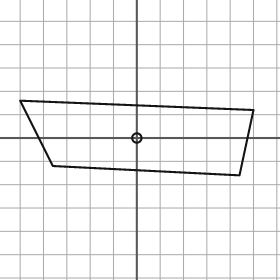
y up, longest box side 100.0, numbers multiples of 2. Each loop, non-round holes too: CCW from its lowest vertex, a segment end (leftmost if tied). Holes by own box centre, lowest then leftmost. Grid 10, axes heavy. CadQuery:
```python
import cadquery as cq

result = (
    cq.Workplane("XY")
    .moveTo(44.0, -16.0)
    .lineTo(50.0, 12.0)
    .lineTo(-50.0, 16.0)
    .lineTo(-36.0, -12.0)
    .close()
    .moveTo(0.0, 0.0)
    .circle(2.0)
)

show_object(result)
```